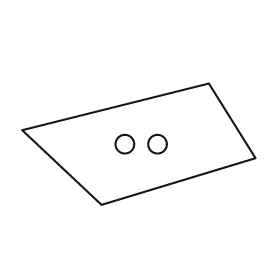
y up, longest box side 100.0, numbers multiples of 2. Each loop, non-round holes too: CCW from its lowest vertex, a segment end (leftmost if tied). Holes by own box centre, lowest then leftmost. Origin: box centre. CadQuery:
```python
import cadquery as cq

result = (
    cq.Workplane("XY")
    .moveTo(-16.0, -26.0)
    .lineTo(50.0, -6.0)
    .lineTo(30.0, 26.0)
    .lineTo(-50.0, 6.0)
    .close()
    .moveTo(-6.0, 0.0)
    .circle(4.0)
    .moveTo(8.0, 0.0)
    .circle(4.0)
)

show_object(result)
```